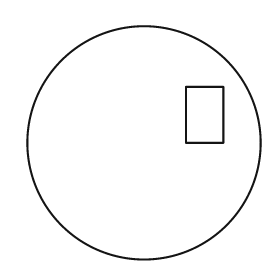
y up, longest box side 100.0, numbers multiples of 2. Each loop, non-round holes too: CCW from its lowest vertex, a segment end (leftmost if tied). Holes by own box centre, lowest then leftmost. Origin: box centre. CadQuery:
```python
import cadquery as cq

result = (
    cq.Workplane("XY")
    .moveTo(0.0, 0.0)
    .circle(50.0)
    .moveTo(18.0, 0.0)
    .lineTo(34.0, 0.0)
    .lineTo(34.0, 24.0)
    .lineTo(18.0, 24.0)
    .close()
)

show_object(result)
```